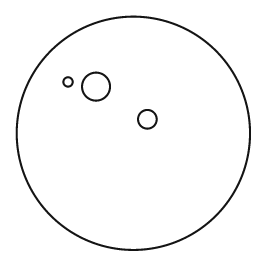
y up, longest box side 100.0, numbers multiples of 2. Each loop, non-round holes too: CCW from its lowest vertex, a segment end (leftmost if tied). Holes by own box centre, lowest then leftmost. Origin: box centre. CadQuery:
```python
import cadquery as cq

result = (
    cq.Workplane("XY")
    .moveTo(0.0, 0.0)
    .circle(50.0)
    .moveTo(6.0, 6.0)
    .circle(4.0)
    .moveTo(-16.0, 20.0)
    .circle(6.0)
    .moveTo(-28.0, 22.0)
    .circle(2.0)
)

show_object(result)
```